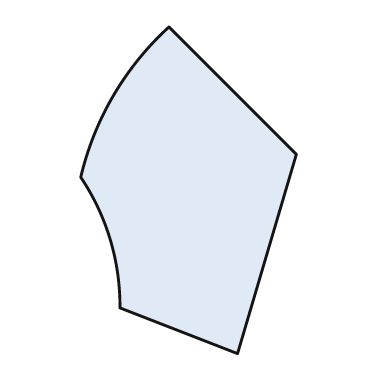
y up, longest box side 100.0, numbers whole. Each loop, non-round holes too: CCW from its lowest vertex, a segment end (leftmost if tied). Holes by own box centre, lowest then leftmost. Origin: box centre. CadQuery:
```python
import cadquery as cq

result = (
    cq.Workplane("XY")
    .moveTo(15.0, -50.0)
    .lineTo(33.0, 11.0)
    .lineTo(-6.0, 50.0)
    .threePointArc((-23.0, 29.0), (-33.0, 4.0))
    .threePointArc((-24.0, -15.0), (-21.0, -36.0))
    .close()
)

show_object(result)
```